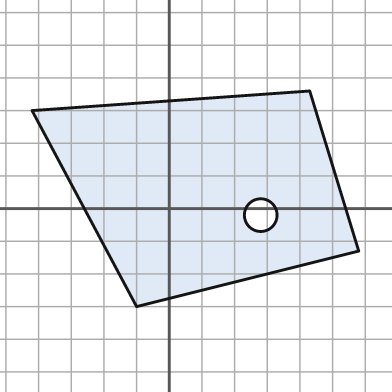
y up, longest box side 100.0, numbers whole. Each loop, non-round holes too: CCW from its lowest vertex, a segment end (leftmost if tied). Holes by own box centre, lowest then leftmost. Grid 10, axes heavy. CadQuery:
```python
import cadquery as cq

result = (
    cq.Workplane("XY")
    .moveTo(-10.0, -30.0)
    .lineTo(58.0, -13.0)
    .lineTo(43.0, 36.0)
    .lineTo(-42.0, 30.0)
    .close()
    .moveTo(28.0, -2.0)
    .circle(5.0)
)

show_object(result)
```